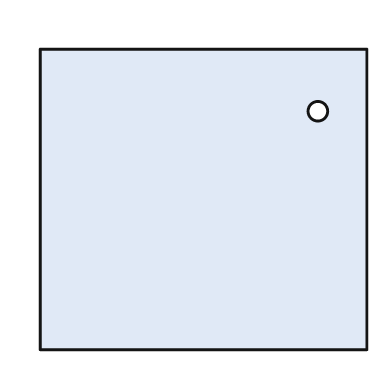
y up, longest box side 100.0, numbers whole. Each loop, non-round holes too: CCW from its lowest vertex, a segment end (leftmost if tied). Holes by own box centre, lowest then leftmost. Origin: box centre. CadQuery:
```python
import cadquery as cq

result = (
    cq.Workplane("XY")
    .moveTo(-50.0, -46.0)
    .lineTo(50.0, -46.0)
    .lineTo(50.0, 46.0)
    .lineTo(-50.0, 46.0)
    .close()
    .moveTo(35.0, 27.0)
    .circle(3.0)
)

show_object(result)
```